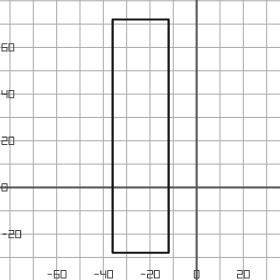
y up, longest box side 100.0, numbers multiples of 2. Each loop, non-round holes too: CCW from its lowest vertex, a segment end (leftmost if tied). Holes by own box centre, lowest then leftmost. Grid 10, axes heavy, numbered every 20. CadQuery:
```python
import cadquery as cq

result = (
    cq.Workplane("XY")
    .moveTo(-36.0, -28.0)
    .lineTo(-12.0, -28.0)
    .lineTo(-12.0, 72.0)
    .lineTo(-36.0, 72.0)
    .close()
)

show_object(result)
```